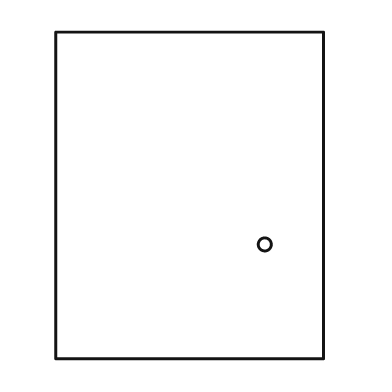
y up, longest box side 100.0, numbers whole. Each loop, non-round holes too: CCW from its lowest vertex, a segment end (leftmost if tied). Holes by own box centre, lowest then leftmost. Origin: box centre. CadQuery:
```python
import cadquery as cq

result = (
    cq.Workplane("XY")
    .moveTo(-41.0, -50.0)
    .lineTo(41.0, -50.0)
    .lineTo(41.0, 50.0)
    .lineTo(-41.0, 50.0)
    .close()
    .moveTo(23.0, -15.0)
    .circle(2.0)
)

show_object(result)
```